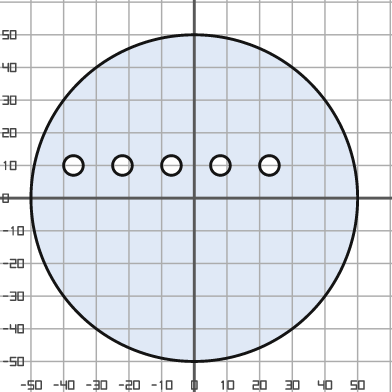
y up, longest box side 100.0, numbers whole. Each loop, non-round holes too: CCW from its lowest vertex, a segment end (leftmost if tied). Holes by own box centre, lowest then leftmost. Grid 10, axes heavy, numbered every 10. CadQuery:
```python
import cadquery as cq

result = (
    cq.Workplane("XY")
    .moveTo(0.0, 0.0)
    .circle(50.0)
    .moveTo(-37.0, 10.0)
    .circle(3.0)
    .moveTo(-22.0, 10.0)
    .circle(3.0)
    .moveTo(-7.0, 10.0)
    .circle(3.0)
    .moveTo(8.0, 10.0)
    .circle(3.0)
    .moveTo(23.0, 10.0)
    .circle(3.0)
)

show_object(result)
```